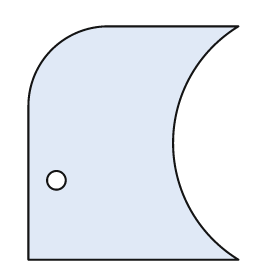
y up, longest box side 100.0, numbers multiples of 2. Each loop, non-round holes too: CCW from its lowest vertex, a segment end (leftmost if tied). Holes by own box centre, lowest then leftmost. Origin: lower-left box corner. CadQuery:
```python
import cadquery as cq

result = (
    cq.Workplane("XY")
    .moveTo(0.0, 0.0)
    .lineTo(90.0, 0.0)
    .threePointArc((62.0, 50.0), (90.0, 100.0))
    .lineTo(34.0, 100.0)
    .threePointArc((10.0, 90.0), (0.0, 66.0))
    .close()
    .moveTo(12.0, 34.0)
    .circle(4.0)
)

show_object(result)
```